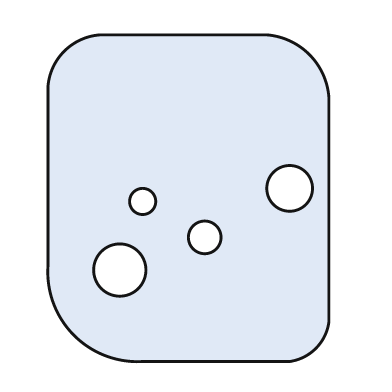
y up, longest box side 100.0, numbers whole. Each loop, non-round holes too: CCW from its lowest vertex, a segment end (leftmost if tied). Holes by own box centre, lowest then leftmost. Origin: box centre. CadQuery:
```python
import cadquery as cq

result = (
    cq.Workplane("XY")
    .moveTo(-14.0, -50.0)
    .lineTo(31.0, -50.0)
    .threePointArc((39.0, -46.0), (43.0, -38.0))
    .lineTo(43.0, 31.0)
    .threePointArc((37.0, 44.0), (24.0, 50.0))
    .lineTo(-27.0, 50.0)
    .threePointArc((-38.0, 45.0), (-43.0, 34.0))
    .lineTo(-43.0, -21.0)
    .threePointArc((-35.0, -42.0), (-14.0, -50.0))
    .close()
    .moveTo(-21.0, -22.0)
    .circle(8.0)
    .moveTo(5.0, -12.0)
    .circle(5.0)
    .moveTo(-14.0, -1.0)
    .circle(4.0)
    .moveTo(31.0, 3.0)
    .circle(7.0)
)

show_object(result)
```